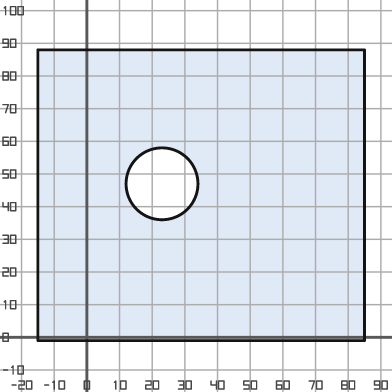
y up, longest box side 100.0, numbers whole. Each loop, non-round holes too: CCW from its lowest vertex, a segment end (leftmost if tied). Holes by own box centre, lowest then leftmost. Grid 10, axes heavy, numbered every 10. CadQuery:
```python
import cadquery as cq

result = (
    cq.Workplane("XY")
    .moveTo(-15.0, -1.0)
    .lineTo(85.0, -1.0)
    .lineTo(85.0, 88.0)
    .lineTo(-15.0, 88.0)
    .close()
    .moveTo(23.0, 47.0)
    .circle(11.0)
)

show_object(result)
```